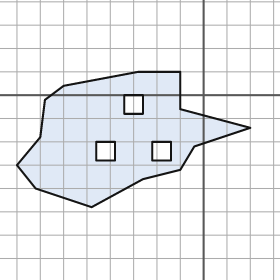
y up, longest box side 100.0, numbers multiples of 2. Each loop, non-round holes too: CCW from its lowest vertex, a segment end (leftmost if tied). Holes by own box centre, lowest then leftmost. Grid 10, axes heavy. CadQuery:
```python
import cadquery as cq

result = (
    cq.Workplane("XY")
    .moveTo(-48.0, -48.0)
    .lineTo(-26.0, -36.0)
    .lineTo(-10.0, -32.0)
    .lineTo(-4.0, -22.0)
    .lineTo(20.0, -14.0)
    .lineTo(-10.0, -6.0)
    .lineTo(-10.0, 10.0)
    .lineTo(-28.0, 10.0)
    .lineTo(-60.0, 4.0)
    .lineTo(-68.0, -2.0)
    .lineTo(-70.0, -18.0)
    .lineTo(-80.0, -30.0)
    .lineTo(-72.0, -40.0)
    .close()
    .moveTo(-46.0, -28.0)
    .lineTo(-38.0, -28.0)
    .lineTo(-38.0, -20.0)
    .lineTo(-46.0, -20.0)
    .close()
    .moveTo(-22.0, -28.0)
    .lineTo(-14.0, -28.0)
    .lineTo(-14.0, -20.0)
    .lineTo(-22.0, -20.0)
    .close()
    .moveTo(-34.0, -8.0)
    .lineTo(-26.0, -8.0)
    .lineTo(-26.0, 0.0)
    .lineTo(-34.0, 0.0)
    .close()
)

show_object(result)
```